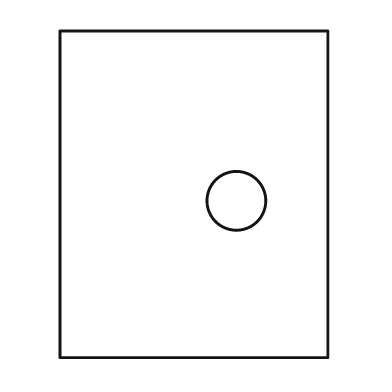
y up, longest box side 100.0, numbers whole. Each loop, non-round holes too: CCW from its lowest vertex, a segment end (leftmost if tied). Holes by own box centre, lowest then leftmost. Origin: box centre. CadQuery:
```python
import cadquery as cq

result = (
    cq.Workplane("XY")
    .moveTo(-41.0, -50.0)
    .lineTo(41.0, -50.0)
    .lineTo(41.0, 50.0)
    .lineTo(-41.0, 50.0)
    .close()
    .moveTo(13.0, -2.0)
    .circle(9.0)
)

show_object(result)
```